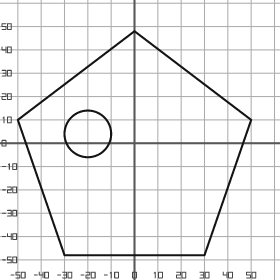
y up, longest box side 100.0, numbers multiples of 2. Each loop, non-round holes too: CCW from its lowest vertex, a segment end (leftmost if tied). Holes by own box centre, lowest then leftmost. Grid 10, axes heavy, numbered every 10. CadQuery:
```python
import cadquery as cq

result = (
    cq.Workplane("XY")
    .moveTo(-30.0, -48.0)
    .lineTo(30.0, -48.0)
    .lineTo(50.0, 10.0)
    .lineTo(0.0, 48.0)
    .lineTo(-50.0, 10.0)
    .close()
    .moveTo(-20.0, 4.0)
    .circle(10.0)
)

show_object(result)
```